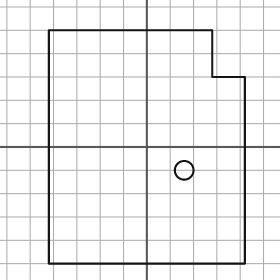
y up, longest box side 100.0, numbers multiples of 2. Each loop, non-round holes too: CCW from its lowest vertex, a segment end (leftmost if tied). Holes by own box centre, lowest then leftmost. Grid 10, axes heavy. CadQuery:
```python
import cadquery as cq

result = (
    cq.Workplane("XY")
    .moveTo(-42.0, -50.0)
    .lineTo(42.0, -50.0)
    .lineTo(42.0, 30.0)
    .lineTo(28.0, 30.0)
    .lineTo(28.0, 50.0)
    .lineTo(-42.0, 50.0)
    .close()
    .moveTo(16.0, -10.0)
    .circle(4.0)
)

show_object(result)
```